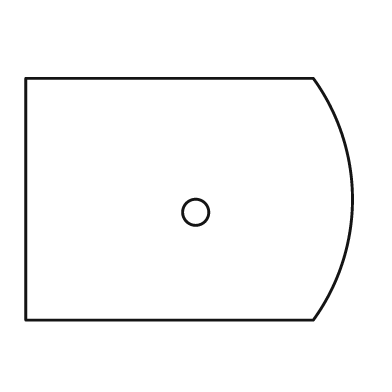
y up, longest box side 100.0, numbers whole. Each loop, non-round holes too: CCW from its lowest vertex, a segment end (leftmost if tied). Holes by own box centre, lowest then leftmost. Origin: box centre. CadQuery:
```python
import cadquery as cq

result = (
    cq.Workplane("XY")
    .moveTo(-50.0, -37.0)
    .lineTo(38.0, -37.0)
    .threePointArc((50.0, 0.0), (38.0, 37.0))
    .lineTo(-50.0, 37.0)
    .close()
    .moveTo(2.0, -4.0)
    .circle(4.0)
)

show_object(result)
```